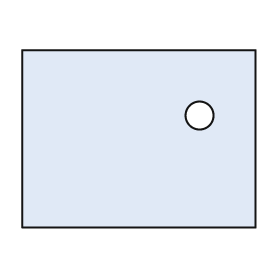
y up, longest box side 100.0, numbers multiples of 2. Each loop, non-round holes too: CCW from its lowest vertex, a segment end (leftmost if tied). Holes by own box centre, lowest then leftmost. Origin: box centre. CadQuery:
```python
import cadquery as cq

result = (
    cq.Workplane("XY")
    .moveTo(-50.0, -38.0)
    .lineTo(50.0, -38.0)
    .lineTo(50.0, 38.0)
    .lineTo(-50.0, 38.0)
    .close()
    .moveTo(26.0, 10.0)
    .circle(6.0)
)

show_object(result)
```